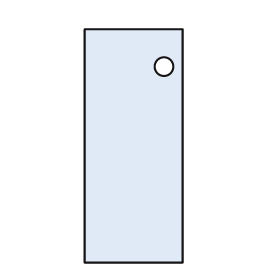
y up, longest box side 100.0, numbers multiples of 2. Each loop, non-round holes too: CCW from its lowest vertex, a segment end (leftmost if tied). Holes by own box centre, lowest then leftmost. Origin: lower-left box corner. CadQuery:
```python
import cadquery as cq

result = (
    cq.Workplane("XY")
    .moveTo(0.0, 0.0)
    .lineTo(42.0, 0.0)
    .lineTo(42.0, 100.0)
    .lineTo(0.0, 100.0)
    .close()
    .moveTo(34.0, 84.0)
    .circle(4.0)
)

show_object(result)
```